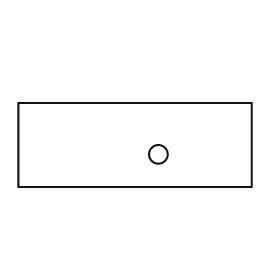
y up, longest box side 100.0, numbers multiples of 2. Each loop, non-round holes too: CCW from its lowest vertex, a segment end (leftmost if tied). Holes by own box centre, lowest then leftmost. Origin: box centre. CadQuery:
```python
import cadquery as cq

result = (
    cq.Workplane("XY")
    .moveTo(-50.0, -18.0)
    .lineTo(50.0, -18.0)
    .lineTo(50.0, 18.0)
    .lineTo(-50.0, 18.0)
    .close()
    .moveTo(10.0, -4.0)
    .circle(4.0)
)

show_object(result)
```